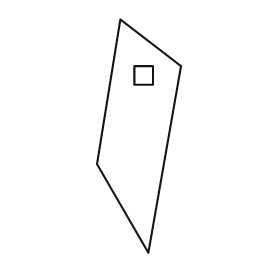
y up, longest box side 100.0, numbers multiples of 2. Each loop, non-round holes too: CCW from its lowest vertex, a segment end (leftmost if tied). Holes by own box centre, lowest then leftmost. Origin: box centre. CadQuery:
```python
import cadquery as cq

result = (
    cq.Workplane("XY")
    .moveTo(4.0, -50.0)
    .lineTo(18.0, 30.0)
    .lineTo(-8.0, 50.0)
    .lineTo(-18.0, -12.0)
    .close()
    .moveTo(-2.0, 22.0)
    .lineTo(6.0, 22.0)
    .lineTo(6.0, 30.0)
    .lineTo(-2.0, 30.0)
    .close()
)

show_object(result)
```